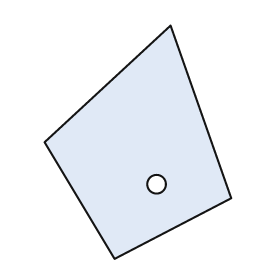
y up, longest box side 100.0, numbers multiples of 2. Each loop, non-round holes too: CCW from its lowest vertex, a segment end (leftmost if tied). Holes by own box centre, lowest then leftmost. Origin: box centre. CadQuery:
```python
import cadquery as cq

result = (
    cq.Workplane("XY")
    .moveTo(-10.0, -50.0)
    .lineTo(40.0, -24.0)
    .lineTo(14.0, 50.0)
    .lineTo(-40.0, 0.0)
    .close()
    .moveTo(8.0, -18.0)
    .circle(4.0)
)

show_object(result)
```